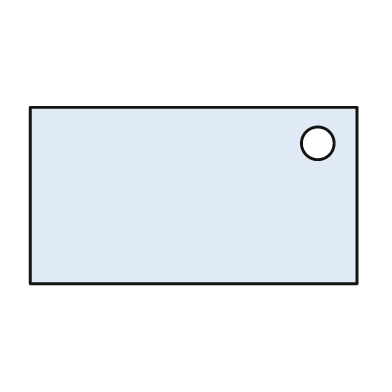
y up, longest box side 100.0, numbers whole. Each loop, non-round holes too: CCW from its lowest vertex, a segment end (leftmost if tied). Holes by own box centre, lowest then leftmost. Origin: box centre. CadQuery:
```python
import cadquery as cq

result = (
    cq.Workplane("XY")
    .moveTo(-50.0, -27.0)
    .lineTo(50.0, -27.0)
    .lineTo(50.0, 27.0)
    .lineTo(-50.0, 27.0)
    .close()
    .moveTo(38.0, 16.0)
    .circle(5.0)
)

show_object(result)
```